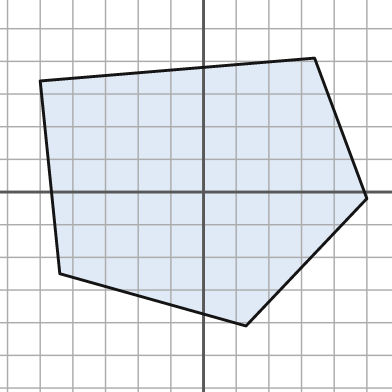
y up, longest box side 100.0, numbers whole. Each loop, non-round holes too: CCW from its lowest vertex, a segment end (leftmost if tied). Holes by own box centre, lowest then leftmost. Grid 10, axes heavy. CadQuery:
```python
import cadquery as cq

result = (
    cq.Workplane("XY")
    .moveTo(13.0, -41.0)
    .lineTo(50.0, -2.0)
    .lineTo(34.0, 41.0)
    .lineTo(-50.0, 34.0)
    .lineTo(-44.0, -25.0)
    .close()
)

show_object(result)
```